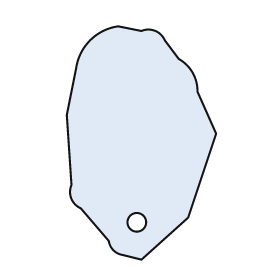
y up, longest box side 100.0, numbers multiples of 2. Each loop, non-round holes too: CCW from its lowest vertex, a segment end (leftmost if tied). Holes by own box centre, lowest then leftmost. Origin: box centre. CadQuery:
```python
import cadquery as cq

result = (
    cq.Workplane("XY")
    .moveTo(0.0, -50.0)
    .lineTo(20.0, -32.0)
    .lineTo(32.0, 4.0)
    .lineTo(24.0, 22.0)
    .threePointArc((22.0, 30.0), (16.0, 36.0))
    .lineTo(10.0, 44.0)
    .threePointArc((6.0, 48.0), (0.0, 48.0))
    .lineTo(-10.0, 50.0)
    .threePointArc((-22.0, 44.0), (-28.0, 32.0))
    .lineTo(-32.0, 12.0)
    .lineTo(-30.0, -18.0)
    .threePointArc((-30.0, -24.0), (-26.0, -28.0))
    .lineTo(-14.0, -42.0)
    .threePointArc((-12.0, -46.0), (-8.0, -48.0))
    .close()
    .moveTo(-2.0, -34.0)
    .circle(4.0)
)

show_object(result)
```